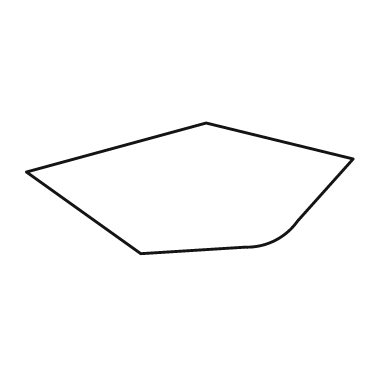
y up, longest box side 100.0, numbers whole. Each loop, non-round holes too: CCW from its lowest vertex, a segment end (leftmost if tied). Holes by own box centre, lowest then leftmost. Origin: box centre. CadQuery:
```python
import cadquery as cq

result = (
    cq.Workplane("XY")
    .moveTo(-15.0, -20.0)
    .lineTo(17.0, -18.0)
    .threePointArc((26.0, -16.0), (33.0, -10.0))
    .lineTo(50.0, 9.0)
    .lineTo(5.0, 20.0)
    .lineTo(-50.0, 5.0)
    .close()
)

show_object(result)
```